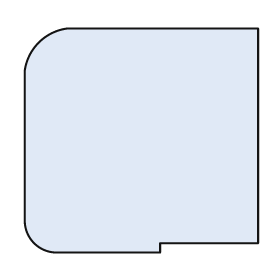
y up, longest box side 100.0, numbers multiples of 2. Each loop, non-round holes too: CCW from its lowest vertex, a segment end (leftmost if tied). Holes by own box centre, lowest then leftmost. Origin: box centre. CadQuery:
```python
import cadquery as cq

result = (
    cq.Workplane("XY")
    .moveTo(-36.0, -48.0)
    .lineTo(8.0, -48.0)
    .lineTo(8.0, -44.0)
    .lineTo(50.0, -44.0)
    .lineTo(50.0, 48.0)
    .lineTo(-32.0, 48.0)
    .threePointArc((-44.0, 42.0), (-50.0, 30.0))
    .lineTo(-50.0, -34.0)
    .threePointArc((-46.0, -44.0), (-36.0, -48.0))
    .close()
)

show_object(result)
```